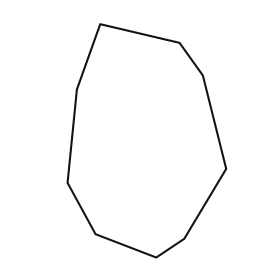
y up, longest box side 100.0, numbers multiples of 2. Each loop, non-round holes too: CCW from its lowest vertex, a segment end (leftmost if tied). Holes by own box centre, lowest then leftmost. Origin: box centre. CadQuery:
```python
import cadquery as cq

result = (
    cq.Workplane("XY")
    .moveTo(4.0, -50.0)
    .lineTo(16.0, -42.0)
    .lineTo(34.0, -12.0)
    .lineTo(24.0, 28.0)
    .lineTo(14.0, 42.0)
    .lineTo(-20.0, 50.0)
    .lineTo(-30.0, 22.0)
    .lineTo(-34.0, -18.0)
    .lineTo(-22.0, -40.0)
    .close()
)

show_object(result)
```